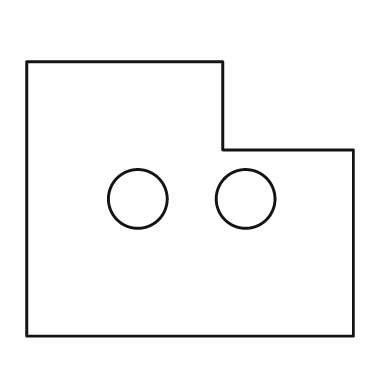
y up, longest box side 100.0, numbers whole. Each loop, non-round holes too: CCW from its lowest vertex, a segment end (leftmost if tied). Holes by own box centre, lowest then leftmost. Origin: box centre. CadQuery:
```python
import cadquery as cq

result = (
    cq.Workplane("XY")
    .moveTo(-50.0, -42.0)
    .lineTo(50.0, -42.0)
    .lineTo(50.0, 15.0)
    .lineTo(10.0, 15.0)
    .lineTo(10.0, 42.0)
    .lineTo(-50.0, 42.0)
    .close()
    .moveTo(-16.0, 0.0)
    .circle(9.0)
    .moveTo(17.0, 0.0)
    .circle(9.0)
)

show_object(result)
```